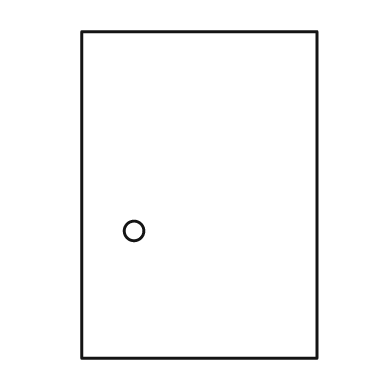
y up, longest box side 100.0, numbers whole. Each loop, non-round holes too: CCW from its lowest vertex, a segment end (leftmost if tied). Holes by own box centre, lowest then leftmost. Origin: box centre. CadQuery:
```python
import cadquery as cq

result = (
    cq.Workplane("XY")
    .moveTo(-36.0, -50.0)
    .lineTo(36.0, -50.0)
    .lineTo(36.0, 50.0)
    .lineTo(-36.0, 50.0)
    .close()
    .moveTo(-20.0, -11.0)
    .circle(3.0)
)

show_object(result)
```